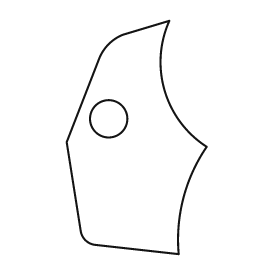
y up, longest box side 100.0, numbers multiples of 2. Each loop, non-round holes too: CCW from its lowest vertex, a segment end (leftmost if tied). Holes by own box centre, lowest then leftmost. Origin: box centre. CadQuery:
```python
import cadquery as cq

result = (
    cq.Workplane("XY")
    .moveTo(18.0, -50.0)
    .threePointArc((20.0, -26.0), (30.0, -4.0))
    .threePointArc((12.0, 20.0), (14.0, 50.0))
    .lineTo(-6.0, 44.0)
    .threePointArc((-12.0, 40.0), (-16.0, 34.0))
    .lineTo(-30.0, -2.0)
    .lineTo(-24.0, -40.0)
    .threePointArc((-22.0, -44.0), (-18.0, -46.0))
    .close()
    .moveTo(-12.0, 8.0)
    .circle(8.0)
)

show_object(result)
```